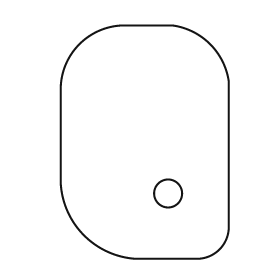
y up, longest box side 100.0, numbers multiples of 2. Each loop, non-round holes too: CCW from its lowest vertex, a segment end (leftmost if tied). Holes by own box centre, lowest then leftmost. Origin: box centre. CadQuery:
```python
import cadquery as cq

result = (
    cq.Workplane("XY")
    .moveTo(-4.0, -50.0)
    .lineTo(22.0, -50.0)
    .threePointArc((32.0, -46.0), (36.0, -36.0))
    .lineTo(36.0, 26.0)
    .threePointArc((28.0, 42.0), (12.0, 50.0))
    .lineTo(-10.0, 50.0)
    .threePointArc((-28.0, 42.0), (-36.0, 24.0))
    .lineTo(-36.0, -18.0)
    .threePointArc((-26.0, -40.0), (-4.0, -50.0))
    .close()
    .moveTo(10.0, -22.0)
    .circle(6.0)
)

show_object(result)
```